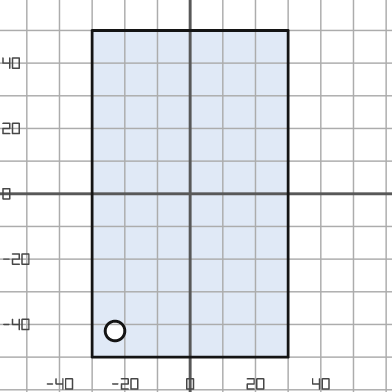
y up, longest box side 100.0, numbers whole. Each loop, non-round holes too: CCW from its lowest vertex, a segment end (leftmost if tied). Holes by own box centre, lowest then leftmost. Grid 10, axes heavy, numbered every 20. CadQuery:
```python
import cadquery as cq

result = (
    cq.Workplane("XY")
    .moveTo(-30.0, -50.0)
    .lineTo(30.0, -50.0)
    .lineTo(30.0, 50.0)
    .lineTo(-30.0, 50.0)
    .close()
    .moveTo(-23.0, -42.0)
    .circle(3.0)
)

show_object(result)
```